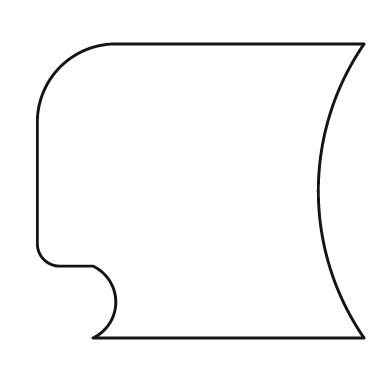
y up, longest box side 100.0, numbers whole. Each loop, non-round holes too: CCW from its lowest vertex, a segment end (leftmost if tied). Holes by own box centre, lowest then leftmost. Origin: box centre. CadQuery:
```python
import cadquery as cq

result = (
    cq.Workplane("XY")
    .moveTo(-33.0, -45.0)
    .lineTo(50.0, -45.0)
    .threePointArc((36.0, 0.0), (50.0, 45.0))
    .lineTo(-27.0, 45.0)
    .threePointArc((-43.0, 38.0), (-50.0, 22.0))
    .lineTo(-50.0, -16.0)
    .threePointArc((-48.0, -21.0), (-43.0, -23.0))
    .lineTo(-33.0, -23.0)
    .threePointArc((-26.0, -34.0), (-33.0, -45.0))
    .close()
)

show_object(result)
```